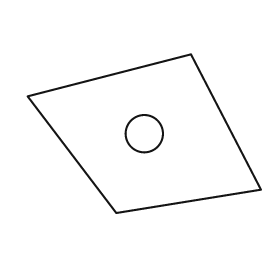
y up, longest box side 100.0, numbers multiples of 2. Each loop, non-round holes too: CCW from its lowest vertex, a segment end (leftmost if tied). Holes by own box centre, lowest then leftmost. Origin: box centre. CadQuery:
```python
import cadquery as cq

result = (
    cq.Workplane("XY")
    .moveTo(-12.0, -34.0)
    .lineTo(50.0, -24.0)
    .lineTo(20.0, 34.0)
    .lineTo(-50.0, 16.0)
    .close()
    .moveTo(0.0, 0.0)
    .circle(8.0)
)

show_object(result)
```